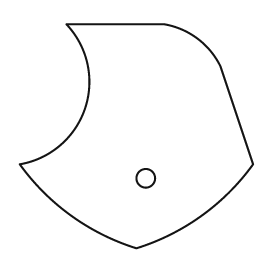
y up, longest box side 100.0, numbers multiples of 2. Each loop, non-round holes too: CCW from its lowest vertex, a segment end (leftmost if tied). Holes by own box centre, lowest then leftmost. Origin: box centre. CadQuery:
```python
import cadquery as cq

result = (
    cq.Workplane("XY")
    .moveTo(0.0, -48.0)
    .threePointArc((28.0, -34.0), (50.0, -12.0))
    .lineTo(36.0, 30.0)
    .threePointArc((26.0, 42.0), (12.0, 48.0))
    .lineTo(-30.0, 48.0)
    .threePointArc((-22.0, 12.0), (-50.0, -12.0))
    .threePointArc((-28.0, -34.0), (0.0, -48.0))
    .close()
    .moveTo(4.0, -18.0)
    .circle(4.0)
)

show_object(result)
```